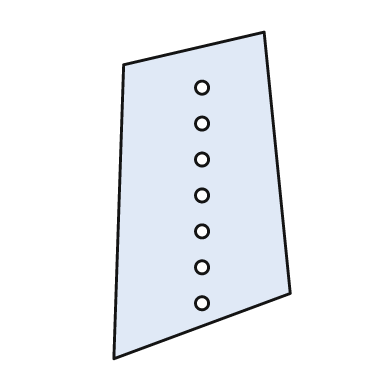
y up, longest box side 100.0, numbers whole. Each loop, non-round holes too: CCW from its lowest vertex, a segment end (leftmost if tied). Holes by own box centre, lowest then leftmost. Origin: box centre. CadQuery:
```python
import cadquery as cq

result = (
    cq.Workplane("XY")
    .moveTo(-27.0, -50.0)
    .lineTo(27.0, -30.0)
    .lineTo(19.0, 50.0)
    .lineTo(-24.0, 40.0)
    .close()
    .moveTo(0.0, -33.0)
    .circle(2.0)
    .moveTo(0.0, -22.0)
    .circle(2.0)
    .moveTo(0.0, -11.0)
    .circle(2.0)
    .moveTo(0.0, 0.0)
    .circle(2.0)
    .moveTo(0.0, 11.0)
    .circle(2.0)
    .moveTo(0.0, 22.0)
    .circle(2.0)
    .moveTo(0.0, 33.0)
    .circle(2.0)
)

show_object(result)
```